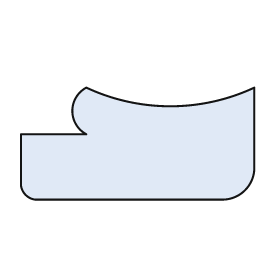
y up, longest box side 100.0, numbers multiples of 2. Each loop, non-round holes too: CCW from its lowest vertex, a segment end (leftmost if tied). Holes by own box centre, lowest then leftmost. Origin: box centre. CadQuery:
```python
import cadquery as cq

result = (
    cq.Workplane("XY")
    .moveTo(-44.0, -24.0)
    .lineTo(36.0, -24.0)
    .threePointArc((46.0, -20.0), (50.0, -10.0))
    .lineTo(50.0, 24.0)
    .threePointArc((14.0, 16.0), (-22.0, 24.0))
    .threePointArc((-28.0, 14.0), (-22.0, 4.0))
    .lineTo(-50.0, 4.0)
    .lineTo(-50.0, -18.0)
    .threePointArc((-48.0, -22.0), (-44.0, -24.0))
    .close()
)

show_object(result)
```